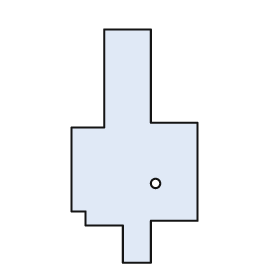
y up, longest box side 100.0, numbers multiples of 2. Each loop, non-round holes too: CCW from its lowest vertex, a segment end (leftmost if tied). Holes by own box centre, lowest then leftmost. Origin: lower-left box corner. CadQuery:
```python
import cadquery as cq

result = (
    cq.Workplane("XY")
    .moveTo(22.0, 0.0)
    .lineTo(34.0, 0.0)
    .lineTo(34.0, 18.0)
    .lineTo(54.0, 18.0)
    .lineTo(54.0, 60.0)
    .lineTo(34.0, 60.0)
    .lineTo(34.0, 100.0)
    .lineTo(14.0, 100.0)
    .lineTo(14.0, 58.0)
    .lineTo(0.0, 58.0)
    .lineTo(0.0, 22.0)
    .lineTo(6.0, 22.0)
    .lineTo(6.0, 16.0)
    .lineTo(22.0, 16.0)
    .close()
    .moveTo(36.0, 34.0)
    .circle(2.0)
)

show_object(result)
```